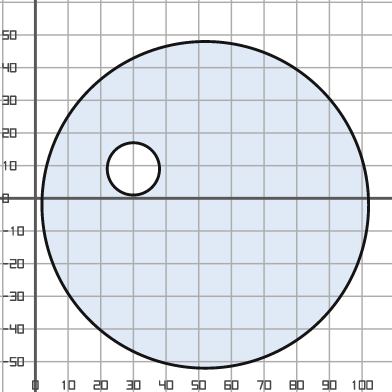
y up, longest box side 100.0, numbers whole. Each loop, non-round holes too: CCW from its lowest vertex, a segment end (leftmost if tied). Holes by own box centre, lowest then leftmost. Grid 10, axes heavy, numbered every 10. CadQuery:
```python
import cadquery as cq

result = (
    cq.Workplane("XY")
    .moveTo(52.0, -2.0)
    .circle(50.0)
    .moveTo(30.0, 9.0)
    .circle(8.0)
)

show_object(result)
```